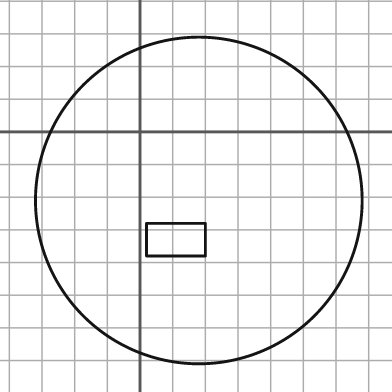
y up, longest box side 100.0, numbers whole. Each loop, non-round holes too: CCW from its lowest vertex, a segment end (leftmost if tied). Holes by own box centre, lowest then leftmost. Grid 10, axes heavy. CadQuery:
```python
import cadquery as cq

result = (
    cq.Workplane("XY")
    .moveTo(18.0, -21.0)
    .circle(50.0)
    .moveTo(2.0, -38.0)
    .lineTo(20.0, -38.0)
    .lineTo(20.0, -28.0)
    .lineTo(2.0, -28.0)
    .close()
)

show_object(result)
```